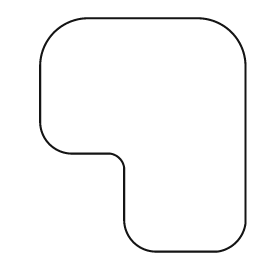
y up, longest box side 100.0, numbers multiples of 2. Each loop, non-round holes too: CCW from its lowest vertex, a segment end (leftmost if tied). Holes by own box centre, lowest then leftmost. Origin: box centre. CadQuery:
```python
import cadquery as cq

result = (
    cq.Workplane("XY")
    .moveTo(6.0, -50.0)
    .lineTo(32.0, -50.0)
    .threePointArc((40.0, -46.0), (44.0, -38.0))
    .lineTo(44.0, 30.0)
    .threePointArc((38.0, 44.0), (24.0, 50.0))
    .lineTo(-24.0, 50.0)
    .threePointArc((-38.0, 44.0), (-44.0, 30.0))
    .lineTo(-44.0, 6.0)
    .threePointArc((-40.0, -4.0), (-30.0, -8.0))
    .lineTo(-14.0, -8.0)
    .threePointArc((-10.0, -10.0), (-8.0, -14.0))
    .lineTo(-8.0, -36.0)
    .threePointArc((-4.0, -46.0), (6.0, -50.0))
    .close()
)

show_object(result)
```